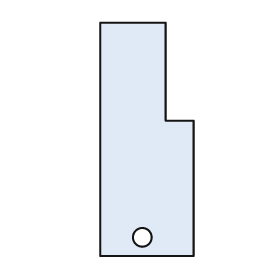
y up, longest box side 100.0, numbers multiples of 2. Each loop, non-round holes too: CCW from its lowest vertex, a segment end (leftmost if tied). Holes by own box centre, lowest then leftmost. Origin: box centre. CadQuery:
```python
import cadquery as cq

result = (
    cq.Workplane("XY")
    .moveTo(-20.0, -50.0)
    .lineTo(20.0, -50.0)
    .lineTo(20.0, 8.0)
    .lineTo(8.0, 8.0)
    .lineTo(8.0, 50.0)
    .lineTo(-20.0, 50.0)
    .close()
    .moveTo(-2.0, -42.0)
    .circle(4.0)
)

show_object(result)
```